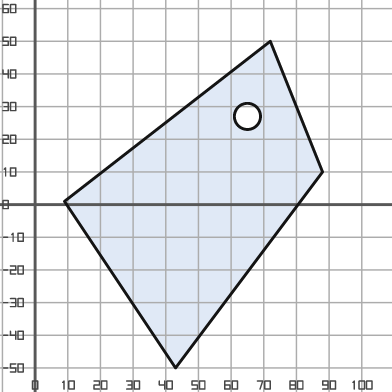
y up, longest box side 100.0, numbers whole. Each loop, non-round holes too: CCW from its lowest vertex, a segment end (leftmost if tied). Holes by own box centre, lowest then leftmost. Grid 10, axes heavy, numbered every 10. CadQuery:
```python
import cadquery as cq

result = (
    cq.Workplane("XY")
    .moveTo(43.0, -50.0)
    .lineTo(88.0, 10.0)
    .lineTo(72.0, 50.0)
    .lineTo(9.0, 1.0)
    .close()
    .moveTo(65.0, 27.0)
    .circle(4.0)
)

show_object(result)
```